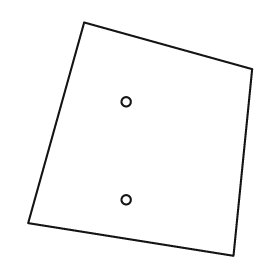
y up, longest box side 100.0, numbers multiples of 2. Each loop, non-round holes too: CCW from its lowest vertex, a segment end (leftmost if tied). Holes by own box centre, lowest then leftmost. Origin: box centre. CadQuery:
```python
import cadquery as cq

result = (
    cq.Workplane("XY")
    .moveTo(40.0, -50.0)
    .lineTo(48.0, 30.0)
    .lineTo(-24.0, 50.0)
    .lineTo(-48.0, -36.0)
    .close()
    .moveTo(-6.0, -26.0)
    .circle(2.0)
    .moveTo(-6.0, 16.0)
    .circle(2.0)
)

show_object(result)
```